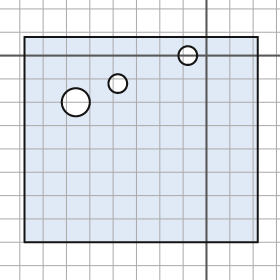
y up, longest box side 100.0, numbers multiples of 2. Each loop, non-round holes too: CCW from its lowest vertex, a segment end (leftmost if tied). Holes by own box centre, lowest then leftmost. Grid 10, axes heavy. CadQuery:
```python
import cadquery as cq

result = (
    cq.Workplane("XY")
    .moveTo(-78.0, -80.0)
    .lineTo(22.0, -80.0)
    .lineTo(22.0, 8.0)
    .lineTo(-78.0, 8.0)
    .close()
    .moveTo(-56.0, -20.0)
    .circle(6.0)
    .moveTo(-38.0, -12.0)
    .circle(4.0)
    .moveTo(-8.0, 0.0)
    .circle(4.0)
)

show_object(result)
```